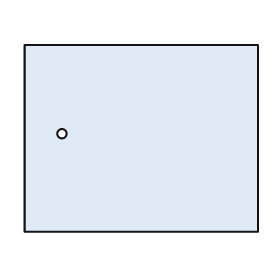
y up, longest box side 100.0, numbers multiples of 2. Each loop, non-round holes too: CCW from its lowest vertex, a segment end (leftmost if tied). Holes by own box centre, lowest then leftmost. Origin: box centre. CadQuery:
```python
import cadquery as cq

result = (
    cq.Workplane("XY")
    .moveTo(-50.0, -40.0)
    .lineTo(50.0, -40.0)
    .lineTo(50.0, 40.0)
    .lineTo(-50.0, 40.0)
    .close()
    .moveTo(-34.0, 2.0)
    .circle(2.0)
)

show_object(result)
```